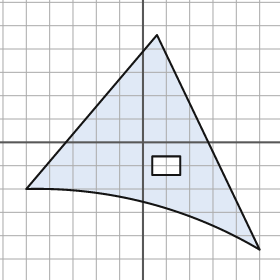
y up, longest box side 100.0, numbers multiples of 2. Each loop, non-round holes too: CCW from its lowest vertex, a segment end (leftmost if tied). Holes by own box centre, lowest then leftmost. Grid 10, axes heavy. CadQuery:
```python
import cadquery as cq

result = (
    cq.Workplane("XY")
    .moveTo(50.0, -46.0)
    .lineTo(6.0, 46.0)
    .lineTo(-50.0, -20.0)
    .threePointArc((2.0, -26.0), (50.0, -46.0))
    .close()
    .moveTo(4.0, -14.0)
    .lineTo(16.0, -14.0)
    .lineTo(16.0, -6.0)
    .lineTo(4.0, -6.0)
    .close()
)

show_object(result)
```